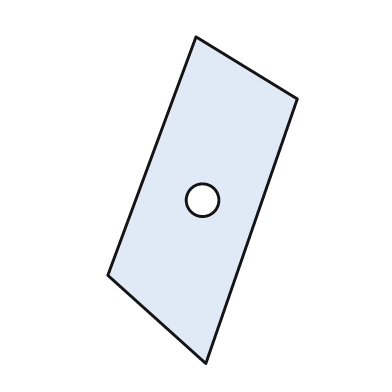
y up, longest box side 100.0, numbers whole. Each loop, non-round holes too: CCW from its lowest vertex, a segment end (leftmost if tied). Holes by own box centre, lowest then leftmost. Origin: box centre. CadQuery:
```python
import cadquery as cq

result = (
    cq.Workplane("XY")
    .moveTo(1.0, -50.0)
    .lineTo(29.0, 31.0)
    .lineTo(-2.0, 50.0)
    .lineTo(-29.0, -23.0)
    .close()
    .moveTo(0.0, 0.0)
    .circle(5.0)
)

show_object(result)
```